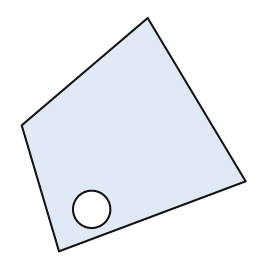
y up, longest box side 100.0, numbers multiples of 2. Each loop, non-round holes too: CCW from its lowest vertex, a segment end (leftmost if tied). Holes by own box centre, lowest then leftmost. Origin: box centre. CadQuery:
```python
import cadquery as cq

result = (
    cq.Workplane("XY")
    .moveTo(-32.0, -50.0)
    .lineTo(48.0, -20.0)
    .lineTo(6.0, 50.0)
    .lineTo(-48.0, 4.0)
    .close()
    .moveTo(-18.0, -32.0)
    .circle(8.0)
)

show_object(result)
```